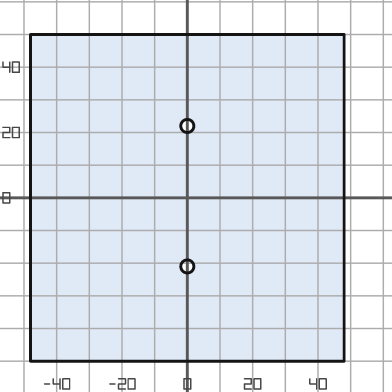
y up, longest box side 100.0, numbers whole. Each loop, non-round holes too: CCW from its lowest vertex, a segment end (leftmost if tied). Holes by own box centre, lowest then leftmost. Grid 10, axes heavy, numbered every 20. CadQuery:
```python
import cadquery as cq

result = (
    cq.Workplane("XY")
    .moveTo(-48.0, -50.0)
    .lineTo(48.0, -50.0)
    .lineTo(48.0, 50.0)
    .lineTo(-48.0, 50.0)
    .close()
    .moveTo(0.0, -21.0)
    .circle(2.0)
    .moveTo(0.0, 22.0)
    .circle(2.0)
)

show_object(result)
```